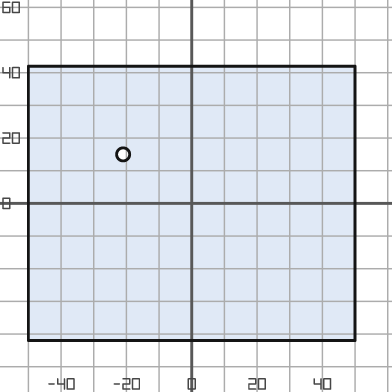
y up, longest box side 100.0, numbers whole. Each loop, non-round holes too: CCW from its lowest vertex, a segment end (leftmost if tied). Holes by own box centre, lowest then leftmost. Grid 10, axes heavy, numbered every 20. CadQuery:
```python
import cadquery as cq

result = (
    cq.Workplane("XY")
    .moveTo(-50.0, -42.0)
    .lineTo(50.0, -42.0)
    .lineTo(50.0, 42.0)
    .lineTo(-50.0, 42.0)
    .close()
    .moveTo(-21.0, 15.0)
    .circle(2.0)
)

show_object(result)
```